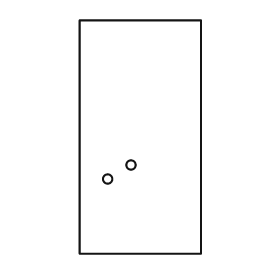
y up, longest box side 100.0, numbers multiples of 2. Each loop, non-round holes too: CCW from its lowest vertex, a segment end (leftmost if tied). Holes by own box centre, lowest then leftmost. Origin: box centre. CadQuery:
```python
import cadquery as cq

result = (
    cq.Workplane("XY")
    .moveTo(-26.0, -50.0)
    .lineTo(26.0, -50.0)
    .lineTo(26.0, 50.0)
    .lineTo(-26.0, 50.0)
    .close()
    .moveTo(-14.0, -18.0)
    .circle(2.0)
    .moveTo(-4.0, -12.0)
    .circle(2.0)
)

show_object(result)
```